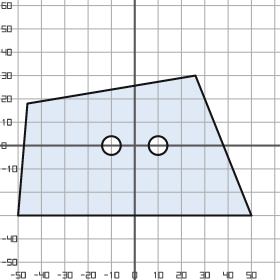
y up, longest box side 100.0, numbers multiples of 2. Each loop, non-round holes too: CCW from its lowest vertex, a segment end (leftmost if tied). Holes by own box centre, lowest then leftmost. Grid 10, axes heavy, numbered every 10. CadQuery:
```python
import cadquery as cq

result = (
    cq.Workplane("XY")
    .moveTo(-50.0, -30.0)
    .lineTo(50.0, -30.0)
    .lineTo(26.0, 30.0)
    .lineTo(-46.0, 18.0)
    .close()
    .moveTo(-10.0, 0.0)
    .circle(4.0)
    .moveTo(10.0, 0.0)
    .circle(4.0)
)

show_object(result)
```